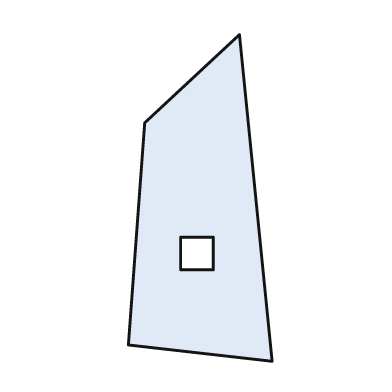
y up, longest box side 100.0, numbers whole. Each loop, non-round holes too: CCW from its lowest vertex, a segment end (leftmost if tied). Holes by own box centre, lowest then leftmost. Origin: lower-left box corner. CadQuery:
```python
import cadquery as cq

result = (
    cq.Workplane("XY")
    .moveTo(44.0, 0.0)
    .lineTo(34.0, 100.0)
    .lineTo(5.0, 73.0)
    .lineTo(0.0, 5.0)
    .close()
    .moveTo(16.0, 28.0)
    .lineTo(26.0, 28.0)
    .lineTo(26.0, 38.0)
    .lineTo(16.0, 38.0)
    .close()
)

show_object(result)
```